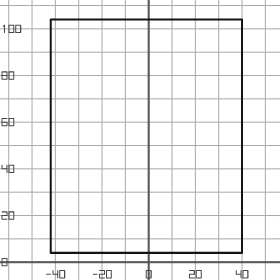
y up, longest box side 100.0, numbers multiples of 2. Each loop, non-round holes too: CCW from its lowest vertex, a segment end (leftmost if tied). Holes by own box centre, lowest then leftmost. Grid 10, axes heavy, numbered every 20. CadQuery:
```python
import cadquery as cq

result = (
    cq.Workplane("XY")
    .moveTo(-42.0, 4.0)
    .lineTo(40.0, 4.0)
    .lineTo(40.0, 104.0)
    .lineTo(-42.0, 104.0)
    .close()
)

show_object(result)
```